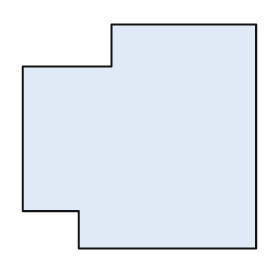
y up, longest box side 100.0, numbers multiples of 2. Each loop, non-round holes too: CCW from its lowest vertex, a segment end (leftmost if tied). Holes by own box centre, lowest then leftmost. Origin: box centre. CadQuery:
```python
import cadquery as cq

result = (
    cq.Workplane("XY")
    .moveTo(-26.0, -48.0)
    .lineTo(50.0, -48.0)
    .lineTo(50.0, 48.0)
    .lineTo(-12.0, 48.0)
    .lineTo(-12.0, 30.0)
    .lineTo(-50.0, 30.0)
    .lineTo(-50.0, -32.0)
    .lineTo(-26.0, -32.0)
    .close()
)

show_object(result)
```